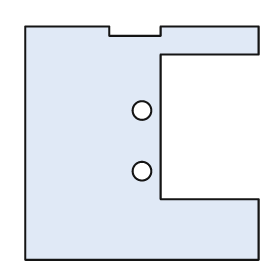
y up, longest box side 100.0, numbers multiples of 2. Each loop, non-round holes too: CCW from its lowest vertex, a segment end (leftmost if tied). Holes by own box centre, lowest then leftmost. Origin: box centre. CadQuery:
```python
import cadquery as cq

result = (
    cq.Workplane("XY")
    .moveTo(-50.0, -50.0)
    .lineTo(50.0, -50.0)
    .lineTo(50.0, -24.0)
    .lineTo(8.0, -24.0)
    .lineTo(8.0, 38.0)
    .lineTo(50.0, 38.0)
    .lineTo(50.0, 50.0)
    .lineTo(8.0, 50.0)
    .lineTo(8.0, 46.0)
    .lineTo(-14.0, 46.0)
    .lineTo(-14.0, 50.0)
    .lineTo(-50.0, 50.0)
    .close()
    .moveTo(0.0, -12.0)
    .circle(4.0)
    .moveTo(0.0, 14.0)
    .circle(4.0)
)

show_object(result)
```